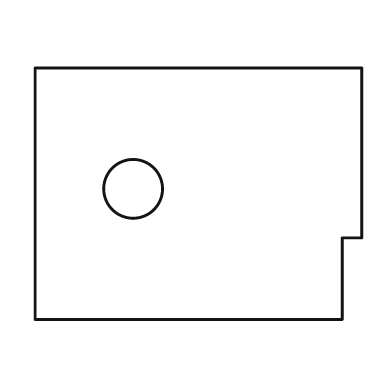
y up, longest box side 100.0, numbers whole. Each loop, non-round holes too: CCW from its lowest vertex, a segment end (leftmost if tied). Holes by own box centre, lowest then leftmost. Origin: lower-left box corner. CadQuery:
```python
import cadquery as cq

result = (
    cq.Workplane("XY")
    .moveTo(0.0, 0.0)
    .lineTo(94.0, 0.0)
    .lineTo(94.0, 25.0)
    .lineTo(100.0, 25.0)
    .lineTo(100.0, 77.0)
    .lineTo(0.0, 77.0)
    .close()
    .moveTo(30.0, 40.0)
    .circle(9.0)
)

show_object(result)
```